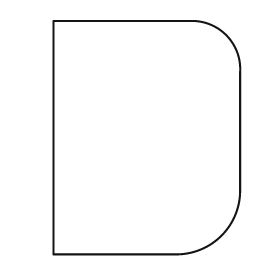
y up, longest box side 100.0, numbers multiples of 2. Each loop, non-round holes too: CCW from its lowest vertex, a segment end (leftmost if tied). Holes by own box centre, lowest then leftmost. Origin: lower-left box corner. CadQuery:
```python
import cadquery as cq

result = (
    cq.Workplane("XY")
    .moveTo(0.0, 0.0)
    .lineTo(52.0, 0.0)
    .threePointArc((72.0, 8.0), (80.0, 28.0))
    .lineTo(80.0, 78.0)
    .threePointArc((74.0, 94.0), (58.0, 100.0))
    .lineTo(0.0, 100.0)
    .close()
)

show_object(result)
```